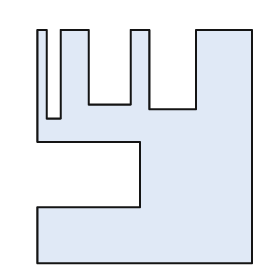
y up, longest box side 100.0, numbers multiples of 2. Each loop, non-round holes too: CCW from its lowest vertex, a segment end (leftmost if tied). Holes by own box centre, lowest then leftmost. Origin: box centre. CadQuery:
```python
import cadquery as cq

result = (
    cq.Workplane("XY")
    .moveTo(-46.0, -50.0)
    .lineTo(46.0, -50.0)
    .lineTo(46.0, 50.0)
    .lineTo(22.0, 50.0)
    .lineTo(22.0, 16.0)
    .lineTo(2.0, 16.0)
    .lineTo(2.0, 50.0)
    .lineTo(-6.0, 50.0)
    .lineTo(-6.0, 18.0)
    .lineTo(-24.0, 18.0)
    .lineTo(-24.0, 50.0)
    .lineTo(-36.0, 50.0)
    .lineTo(-36.0, 12.0)
    .lineTo(-42.0, 12.0)
    .lineTo(-42.0, 50.0)
    .lineTo(-46.0, 50.0)
    .lineTo(-46.0, 2.0)
    .lineTo(-2.0, 2.0)
    .lineTo(-2.0, -26.0)
    .lineTo(-46.0, -26.0)
    .close()
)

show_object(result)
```